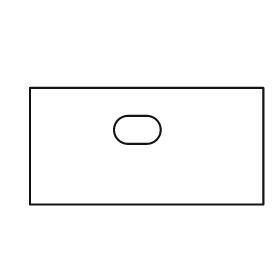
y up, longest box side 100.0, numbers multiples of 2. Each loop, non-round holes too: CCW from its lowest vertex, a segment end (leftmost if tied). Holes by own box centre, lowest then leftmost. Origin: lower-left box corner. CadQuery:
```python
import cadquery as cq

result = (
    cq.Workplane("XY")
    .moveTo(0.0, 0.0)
    .lineTo(100.0, 0.0)
    .lineTo(100.0, 50.0)
    .lineTo(0.0, 50.0)
    .close()
    .moveTo(42.0, 26.0)
    .lineTo(50.0, 26.0)
    .threePointArc((56.0, 32.0), (50.0, 38.0))
    .lineTo(42.0, 38.0)
    .threePointArc((36.0, 32.0), (42.0, 26.0))
    .close()
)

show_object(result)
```